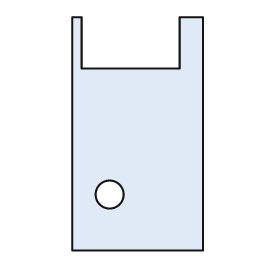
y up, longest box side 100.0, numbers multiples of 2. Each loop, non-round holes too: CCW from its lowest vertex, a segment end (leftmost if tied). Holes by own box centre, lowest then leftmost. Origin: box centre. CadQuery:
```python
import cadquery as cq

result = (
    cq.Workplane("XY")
    .moveTo(-28.0, -50.0)
    .lineTo(28.0, -50.0)
    .lineTo(28.0, 50.0)
    .lineTo(18.0, 50.0)
    .lineTo(18.0, 28.0)
    .lineTo(-24.0, 28.0)
    .lineTo(-24.0, 50.0)
    .lineTo(-28.0, 50.0)
    .close()
    .moveTo(-12.0, -26.0)
    .circle(6.0)
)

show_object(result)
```